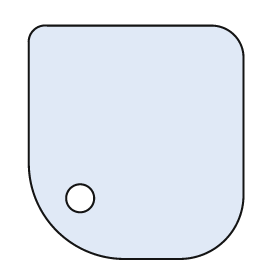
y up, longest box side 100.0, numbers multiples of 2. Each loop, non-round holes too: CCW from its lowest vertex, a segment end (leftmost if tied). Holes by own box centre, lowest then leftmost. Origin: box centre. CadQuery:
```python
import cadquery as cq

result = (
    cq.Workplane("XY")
    .moveTo(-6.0, -50.0)
    .lineTo(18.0, -50.0)
    .threePointArc((38.0, -42.0), (46.0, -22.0))
    .lineTo(46.0, 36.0)
    .threePointArc((42.0, 46.0), (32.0, 50.0))
    .lineTo(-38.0, 50.0)
    .threePointArc((-44.0, 48.0), (-46.0, 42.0))
    .lineTo(-46.0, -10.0)
    .threePointArc((-34.0, -38.0), (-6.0, -50.0))
    .close()
    .moveTo(-24.0, -24.0)
    .circle(6.0)
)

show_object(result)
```